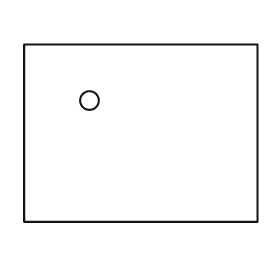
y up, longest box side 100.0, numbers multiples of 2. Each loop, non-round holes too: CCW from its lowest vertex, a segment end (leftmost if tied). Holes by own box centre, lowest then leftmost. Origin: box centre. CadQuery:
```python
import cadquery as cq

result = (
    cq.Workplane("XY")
    .moveTo(-50.0, -38.0)
    .lineTo(50.0, -38.0)
    .lineTo(50.0, 38.0)
    .lineTo(-50.0, 38.0)
    .close()
    .moveTo(-22.0, 14.0)
    .circle(4.0)
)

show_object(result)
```